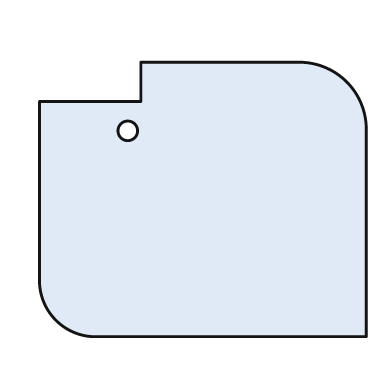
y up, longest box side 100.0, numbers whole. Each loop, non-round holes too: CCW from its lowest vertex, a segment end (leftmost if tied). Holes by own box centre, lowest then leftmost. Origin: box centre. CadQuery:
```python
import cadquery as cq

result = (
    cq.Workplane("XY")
    .moveTo(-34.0, -42.0)
    .lineTo(50.0, -42.0)
    .lineTo(50.0, 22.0)
    .threePointArc((44.0, 36.0), (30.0, 42.0))
    .lineTo(-19.0, 42.0)
    .lineTo(-19.0, 30.0)
    .lineTo(-50.0, 30.0)
    .lineTo(-50.0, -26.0)
    .threePointArc((-45.0, -37.0), (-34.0, -42.0))
    .close()
    .moveTo(-23.0, 21.0)
    .circle(3.0)
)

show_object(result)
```